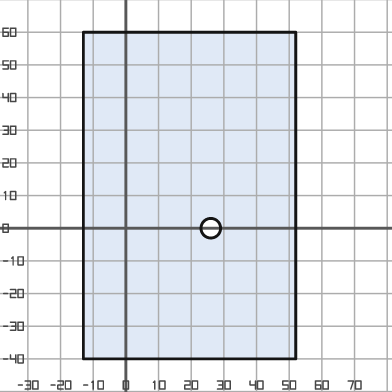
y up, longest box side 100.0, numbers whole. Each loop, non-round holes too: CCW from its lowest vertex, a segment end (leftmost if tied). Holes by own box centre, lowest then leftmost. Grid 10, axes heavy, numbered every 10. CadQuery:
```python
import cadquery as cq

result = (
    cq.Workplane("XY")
    .moveTo(-13.0, -40.0)
    .lineTo(52.0, -40.0)
    .lineTo(52.0, 60.0)
    .lineTo(-13.0, 60.0)
    .close()
    .moveTo(26.0, 0.0)
    .circle(3.0)
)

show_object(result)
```